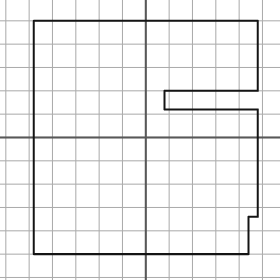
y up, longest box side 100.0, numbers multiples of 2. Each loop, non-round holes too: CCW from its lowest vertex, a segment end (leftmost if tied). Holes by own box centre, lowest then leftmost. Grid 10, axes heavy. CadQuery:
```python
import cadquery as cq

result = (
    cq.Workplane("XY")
    .moveTo(-48.0, -50.0)
    .lineTo(44.0, -50.0)
    .lineTo(44.0, -34.0)
    .lineTo(48.0, -34.0)
    .lineTo(48.0, 12.0)
    .lineTo(8.0, 12.0)
    .lineTo(8.0, 20.0)
    .lineTo(48.0, 20.0)
    .lineTo(48.0, 50.0)
    .lineTo(-48.0, 50.0)
    .close()
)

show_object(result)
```